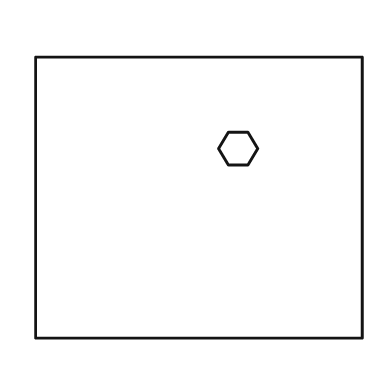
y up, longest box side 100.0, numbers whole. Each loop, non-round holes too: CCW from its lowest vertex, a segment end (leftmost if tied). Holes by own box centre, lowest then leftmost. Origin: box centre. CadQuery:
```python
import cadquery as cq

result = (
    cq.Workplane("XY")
    .moveTo(-50.0, -43.0)
    .lineTo(50.0, -43.0)
    .lineTo(50.0, 43.0)
    .lineTo(-50.0, 43.0)
    .close()
    .moveTo(9.0, 10.0)
    .lineTo(15.0, 10.0)
    .lineTo(18.0, 15.0)
    .lineTo(15.0, 20.0)
    .lineTo(9.0, 20.0)
    .lineTo(6.0, 15.0)
    .close()
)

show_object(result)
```